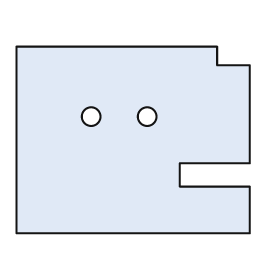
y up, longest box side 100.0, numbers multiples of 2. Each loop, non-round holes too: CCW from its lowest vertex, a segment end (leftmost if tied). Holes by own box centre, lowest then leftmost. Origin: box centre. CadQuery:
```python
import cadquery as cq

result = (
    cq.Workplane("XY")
    .moveTo(-50.0, -40.0)
    .lineTo(50.0, -40.0)
    .lineTo(50.0, -20.0)
    .lineTo(20.0, -20.0)
    .lineTo(20.0, -10.0)
    .lineTo(50.0, -10.0)
    .lineTo(50.0, 32.0)
    .lineTo(36.0, 32.0)
    .lineTo(36.0, 40.0)
    .lineTo(-50.0, 40.0)
    .close()
    .moveTo(-18.0, 10.0)
    .circle(4.0)
    .moveTo(6.0, 10.0)
    .circle(4.0)
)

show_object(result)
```